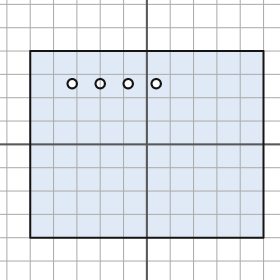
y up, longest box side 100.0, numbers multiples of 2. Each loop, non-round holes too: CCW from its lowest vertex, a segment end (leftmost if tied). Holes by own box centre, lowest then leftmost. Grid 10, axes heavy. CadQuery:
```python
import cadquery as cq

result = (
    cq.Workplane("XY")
    .moveTo(-50.0, -40.0)
    .lineTo(50.0, -40.0)
    .lineTo(50.0, 40.0)
    .lineTo(-50.0, 40.0)
    .close()
    .moveTo(-32.0, 26.0)
    .circle(2.0)
    .moveTo(-20.0, 26.0)
    .circle(2.0)
    .moveTo(-8.0, 26.0)
    .circle(2.0)
    .moveTo(4.0, 26.0)
    .circle(2.0)
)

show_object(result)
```